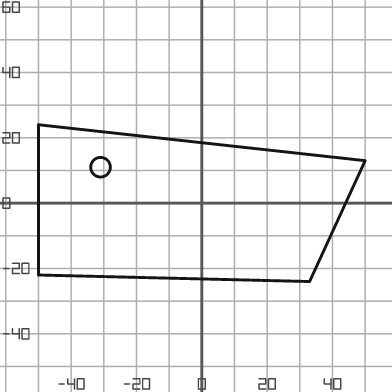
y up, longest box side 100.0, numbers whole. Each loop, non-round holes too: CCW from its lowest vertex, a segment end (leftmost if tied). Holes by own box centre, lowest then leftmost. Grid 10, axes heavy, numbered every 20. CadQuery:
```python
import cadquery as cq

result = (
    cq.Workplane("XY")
    .moveTo(33.0, -24.0)
    .lineTo(50.0, 13.0)
    .lineTo(-50.0, 24.0)
    .lineTo(-50.0, -22.0)
    .close()
    .moveTo(-31.0, 11.0)
    .circle(3.0)
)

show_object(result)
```